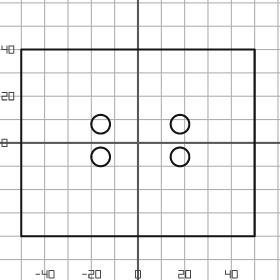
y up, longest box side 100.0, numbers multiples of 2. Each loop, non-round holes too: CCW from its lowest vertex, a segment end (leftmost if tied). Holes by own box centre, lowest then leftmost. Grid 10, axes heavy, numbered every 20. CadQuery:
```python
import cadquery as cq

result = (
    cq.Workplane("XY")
    .moveTo(-50.0, -40.0)
    .lineTo(50.0, -40.0)
    .lineTo(50.0, 40.0)
    .lineTo(-50.0, 40.0)
    .close()
    .moveTo(-16.0, -6.0)
    .circle(4.0)
    .moveTo(18.0, -6.0)
    .circle(4.0)
    .moveTo(-16.0, 8.0)
    .circle(4.0)
    .moveTo(18.0, 8.0)
    .circle(4.0)
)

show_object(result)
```